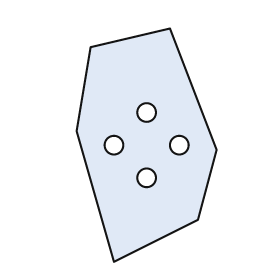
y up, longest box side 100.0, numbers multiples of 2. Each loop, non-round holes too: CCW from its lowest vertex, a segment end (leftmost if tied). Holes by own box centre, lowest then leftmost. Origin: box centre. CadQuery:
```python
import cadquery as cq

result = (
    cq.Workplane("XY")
    .moveTo(-14.0, -50.0)
    .lineTo(22.0, -32.0)
    .lineTo(30.0, -2.0)
    .lineTo(10.0, 50.0)
    .lineTo(-24.0, 42.0)
    .lineTo(-30.0, 6.0)
    .close()
    .moveTo(0.0, -14.0)
    .circle(4.0)
    .moveTo(-14.0, 0.0)
    .circle(4.0)
    .moveTo(14.0, 0.0)
    .circle(4.0)
    .moveTo(0.0, 14.0)
    .circle(4.0)
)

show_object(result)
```